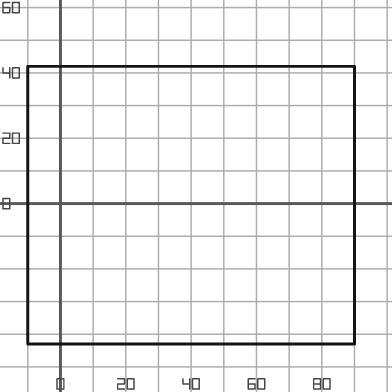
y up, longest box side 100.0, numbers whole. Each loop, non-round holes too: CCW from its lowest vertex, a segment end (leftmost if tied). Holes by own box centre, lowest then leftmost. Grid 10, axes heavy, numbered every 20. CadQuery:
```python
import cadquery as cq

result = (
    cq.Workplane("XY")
    .moveTo(-10.0, -43.0)
    .lineTo(90.0, -43.0)
    .lineTo(90.0, 42.0)
    .lineTo(-10.0, 42.0)
    .close()
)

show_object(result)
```